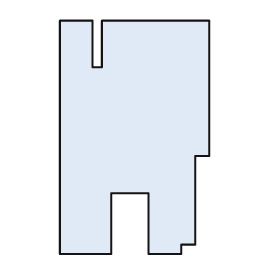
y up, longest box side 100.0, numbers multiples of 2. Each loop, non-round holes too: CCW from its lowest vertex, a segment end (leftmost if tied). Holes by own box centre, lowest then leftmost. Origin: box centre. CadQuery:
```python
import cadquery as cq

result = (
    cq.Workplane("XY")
    .moveTo(-32.0, -50.0)
    .lineTo(-10.0, -50.0)
    .lineTo(-10.0, -24.0)
    .lineTo(6.0, -24.0)
    .lineTo(6.0, -50.0)
    .lineTo(20.0, -50.0)
    .lineTo(20.0, -46.0)
    .lineTo(26.0, -46.0)
    .lineTo(26.0, -8.0)
    .lineTo(32.0, -8.0)
    .lineTo(32.0, 50.0)
    .lineTo(-14.0, 50.0)
    .lineTo(-14.0, 30.0)
    .lineTo(-18.0, 30.0)
    .lineTo(-18.0, 50.0)
    .lineTo(-32.0, 50.0)
    .close()
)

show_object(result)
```